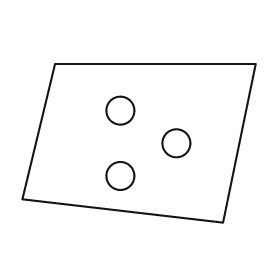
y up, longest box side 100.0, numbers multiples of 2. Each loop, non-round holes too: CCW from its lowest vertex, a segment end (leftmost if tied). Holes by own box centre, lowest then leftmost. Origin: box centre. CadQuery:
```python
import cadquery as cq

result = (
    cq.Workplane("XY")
    .moveTo(36.0, -34.0)
    .lineTo(50.0, 34.0)
    .lineTo(-36.0, 34.0)
    .lineTo(-50.0, -24.0)
    .close()
    .moveTo(-8.0, -14.0)
    .circle(6.0)
    .moveTo(16.0, 0.0)
    .circle(6.0)
    .moveTo(-8.0, 14.0)
    .circle(6.0)
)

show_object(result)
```